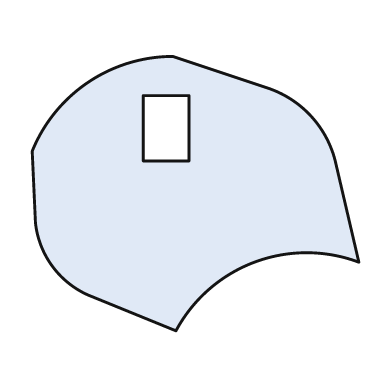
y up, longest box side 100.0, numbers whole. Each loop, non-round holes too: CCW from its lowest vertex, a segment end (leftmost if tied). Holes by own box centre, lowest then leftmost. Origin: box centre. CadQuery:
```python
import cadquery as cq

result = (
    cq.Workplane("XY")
    .moveTo(-6.0, -42.0)
    .threePointArc((18.0, -21.0), (50.0, -21.0))
    .lineTo(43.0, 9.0)
    .threePointArc((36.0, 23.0), (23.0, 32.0))
    .lineTo(-7.0, 42.0)
    .threePointArc((-33.0, 34.0), (-50.0, 13.0))
    .lineTo(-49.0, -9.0)
    .threePointArc((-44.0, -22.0), (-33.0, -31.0))
    .close()
    .moveTo(-16.0, 10.0)
    .lineTo(-2.0, 10.0)
    .lineTo(-2.0, 30.0)
    .lineTo(-16.0, 30.0)
    .close()
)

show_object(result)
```